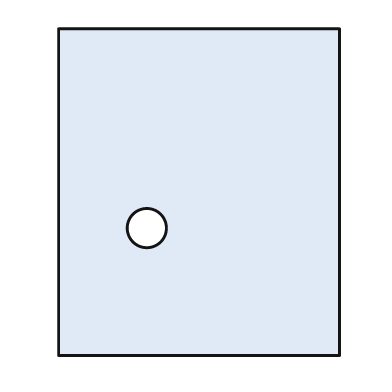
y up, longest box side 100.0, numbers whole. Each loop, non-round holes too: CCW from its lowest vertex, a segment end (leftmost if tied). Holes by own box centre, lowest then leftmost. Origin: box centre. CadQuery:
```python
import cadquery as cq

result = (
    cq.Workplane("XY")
    .moveTo(-43.0, -50.0)
    .lineTo(43.0, -50.0)
    .lineTo(43.0, 50.0)
    .lineTo(-43.0, 50.0)
    .close()
    .moveTo(-16.0, -11.0)
    .circle(6.0)
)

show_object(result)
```